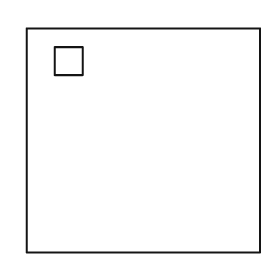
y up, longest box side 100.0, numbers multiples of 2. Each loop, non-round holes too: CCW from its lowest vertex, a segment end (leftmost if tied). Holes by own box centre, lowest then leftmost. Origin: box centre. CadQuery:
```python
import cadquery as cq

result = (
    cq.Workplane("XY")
    .moveTo(-50.0, -48.0)
    .lineTo(50.0, -48.0)
    .lineTo(50.0, 48.0)
    .lineTo(-50.0, 48.0)
    .close()
    .moveTo(-38.0, 28.0)
    .lineTo(-26.0, 28.0)
    .lineTo(-26.0, 40.0)
    .lineTo(-38.0, 40.0)
    .close()
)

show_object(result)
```